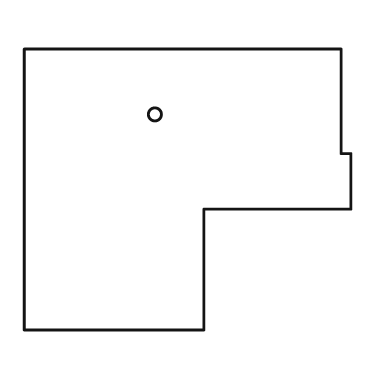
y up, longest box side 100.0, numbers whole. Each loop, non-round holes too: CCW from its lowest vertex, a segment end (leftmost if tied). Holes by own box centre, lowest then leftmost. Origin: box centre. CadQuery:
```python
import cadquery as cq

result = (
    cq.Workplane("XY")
    .moveTo(-50.0, -43.0)
    .lineTo(5.0, -43.0)
    .lineTo(5.0, -6.0)
    .lineTo(50.0, -6.0)
    .lineTo(50.0, 11.0)
    .lineTo(47.0, 11.0)
    .lineTo(47.0, 43.0)
    .lineTo(-50.0, 43.0)
    .close()
    .moveTo(-10.0, 23.0)
    .circle(2.0)
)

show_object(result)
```